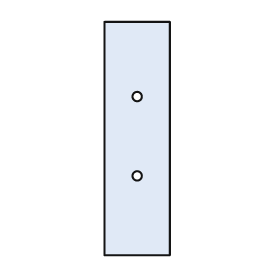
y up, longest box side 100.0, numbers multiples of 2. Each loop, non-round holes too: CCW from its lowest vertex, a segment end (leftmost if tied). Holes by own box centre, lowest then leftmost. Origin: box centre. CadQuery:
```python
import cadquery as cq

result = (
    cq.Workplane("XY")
    .moveTo(-14.0, -50.0)
    .lineTo(14.0, -50.0)
    .lineTo(14.0, 50.0)
    .lineTo(-14.0, 50.0)
    .close()
    .moveTo(0.0, -16.0)
    .circle(2.0)
    .moveTo(0.0, 18.0)
    .circle(2.0)
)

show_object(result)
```